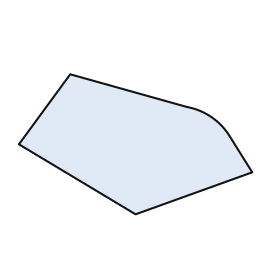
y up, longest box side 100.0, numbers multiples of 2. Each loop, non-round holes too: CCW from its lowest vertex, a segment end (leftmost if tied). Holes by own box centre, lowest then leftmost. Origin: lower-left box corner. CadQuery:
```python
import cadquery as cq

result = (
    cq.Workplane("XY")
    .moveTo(50.0, 0.0)
    .lineTo(100.0, 18.0)
    .lineTo(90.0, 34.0)
    .threePointArc((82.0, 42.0), (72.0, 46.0))
    .lineTo(22.0, 60.0)
    .lineTo(0.0, 30.0)
    .close()
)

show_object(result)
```